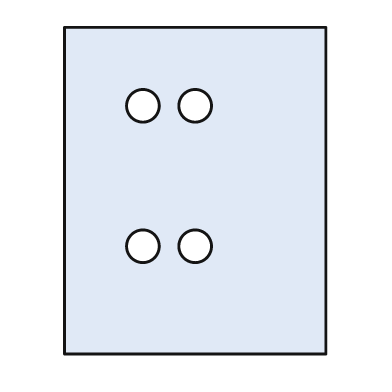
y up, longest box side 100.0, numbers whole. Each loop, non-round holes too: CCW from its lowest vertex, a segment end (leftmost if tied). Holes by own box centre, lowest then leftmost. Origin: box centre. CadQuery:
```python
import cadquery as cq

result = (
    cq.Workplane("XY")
    .moveTo(-40.0, -50.0)
    .lineTo(40.0, -50.0)
    .lineTo(40.0, 50.0)
    .lineTo(-40.0, 50.0)
    .close()
    .moveTo(-16.0, -17.0)
    .circle(5.0)
    .moveTo(0.0, -17.0)
    .circle(5.0)
    .moveTo(-16.0, 26.0)
    .circle(5.0)
    .moveTo(0.0, 26.0)
    .circle(5.0)
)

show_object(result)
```